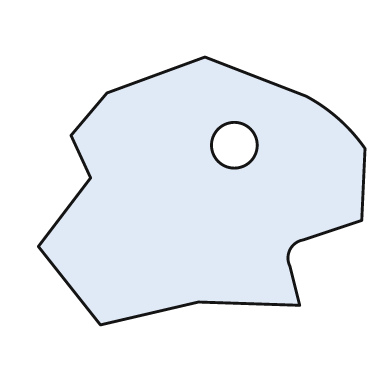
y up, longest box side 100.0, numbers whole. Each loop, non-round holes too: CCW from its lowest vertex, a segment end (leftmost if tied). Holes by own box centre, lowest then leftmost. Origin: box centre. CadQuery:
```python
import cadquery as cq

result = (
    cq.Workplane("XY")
    .moveTo(-31.0, -41.0)
    .lineTo(-1.0, -34.0)
    .lineTo(30.0, -35.0)
    .lineTo(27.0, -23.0)
    .threePointArc((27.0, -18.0), (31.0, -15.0))
    .lineTo(49.0, -9.0)
    .lineTo(50.0, 13.0)
    .threePointArc((42.0, 22.0), (32.0, 29.0))
    .lineTo(1.0, 41.0)
    .lineTo(-29.0, 30.0)
    .lineTo(-40.0, 17.0)
    .lineTo(-34.0, 4.0)
    .lineTo(-50.0, -17.0)
    .close()
    .moveTo(10.0, 14.0)
    .circle(7.0)
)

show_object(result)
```